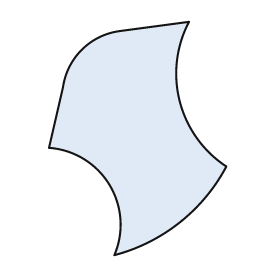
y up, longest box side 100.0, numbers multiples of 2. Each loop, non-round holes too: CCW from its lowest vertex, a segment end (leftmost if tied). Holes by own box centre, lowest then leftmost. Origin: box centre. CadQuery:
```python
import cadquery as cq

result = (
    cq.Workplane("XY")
    .moveTo(-10.0, -50.0)
    .threePointArc((18.0, -36.0), (38.0, -12.0))
    .threePointArc((18.0, 16.0), (22.0, 50.0))
    .lineTo(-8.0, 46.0)
    .threePointArc((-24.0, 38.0), (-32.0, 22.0))
    .lineTo(-38.0, -4.0)
    .threePointArc((-12.0, -20.0), (-10.0, -50.0))
    .close()
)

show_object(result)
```